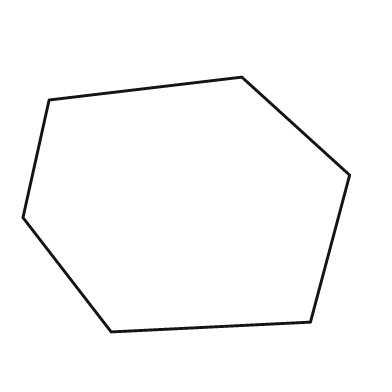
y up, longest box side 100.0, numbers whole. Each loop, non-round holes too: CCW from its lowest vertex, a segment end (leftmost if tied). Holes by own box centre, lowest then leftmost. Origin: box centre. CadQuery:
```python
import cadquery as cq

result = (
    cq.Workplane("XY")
    .moveTo(-23.0, -39.0)
    .lineTo(38.0, -36.0)
    .lineTo(50.0, 9.0)
    .lineTo(17.0, 39.0)
    .lineTo(-42.0, 32.0)
    .lineTo(-50.0, -4.0)
    .close()
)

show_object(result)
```